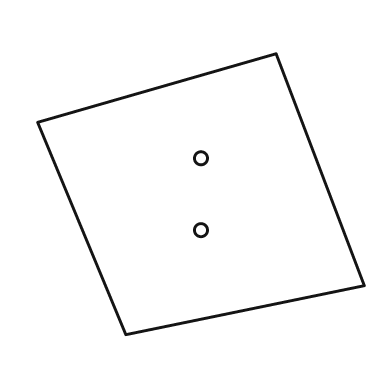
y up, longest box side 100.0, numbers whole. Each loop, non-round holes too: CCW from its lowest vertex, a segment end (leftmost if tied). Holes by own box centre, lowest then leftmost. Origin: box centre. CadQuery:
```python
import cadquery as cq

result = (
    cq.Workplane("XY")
    .moveTo(-23.0, -43.0)
    .lineTo(50.0, -28.0)
    .lineTo(23.0, 43.0)
    .lineTo(-50.0, 22.0)
    .close()
    .moveTo(0.0, -11.0)
    .circle(2.0)
    .moveTo(0.0, 11.0)
    .circle(2.0)
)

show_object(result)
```